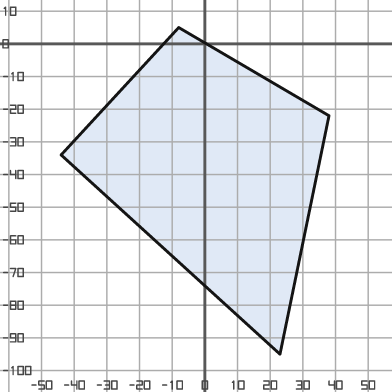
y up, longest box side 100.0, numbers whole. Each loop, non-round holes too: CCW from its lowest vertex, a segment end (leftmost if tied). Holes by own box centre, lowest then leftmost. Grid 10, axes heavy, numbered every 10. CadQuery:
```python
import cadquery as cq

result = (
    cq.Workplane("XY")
    .moveTo(23.0, -95.0)
    .lineTo(38.0, -22.0)
    .lineTo(-8.0, 5.0)
    .lineTo(-44.0, -34.0)
    .close()
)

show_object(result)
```